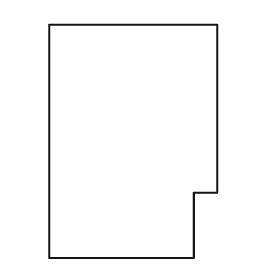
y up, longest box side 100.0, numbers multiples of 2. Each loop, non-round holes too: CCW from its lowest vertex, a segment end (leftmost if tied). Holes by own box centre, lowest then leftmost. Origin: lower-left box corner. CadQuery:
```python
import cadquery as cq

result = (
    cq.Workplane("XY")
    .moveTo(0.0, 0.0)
    .lineTo(62.0, 0.0)
    .lineTo(62.0, 28.0)
    .lineTo(72.0, 28.0)
    .lineTo(72.0, 100.0)
    .lineTo(0.0, 100.0)
    .close()
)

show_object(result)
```